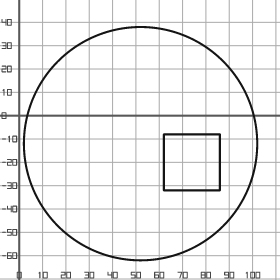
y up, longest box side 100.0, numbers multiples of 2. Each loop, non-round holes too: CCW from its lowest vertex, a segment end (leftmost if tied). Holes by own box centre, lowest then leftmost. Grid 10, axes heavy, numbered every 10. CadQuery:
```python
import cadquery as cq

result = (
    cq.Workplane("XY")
    .moveTo(52.0, -12.0)
    .circle(50.0)
    .moveTo(62.0, -32.0)
    .lineTo(86.0, -32.0)
    .lineTo(86.0, -8.0)
    .lineTo(62.0, -8.0)
    .close()
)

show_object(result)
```